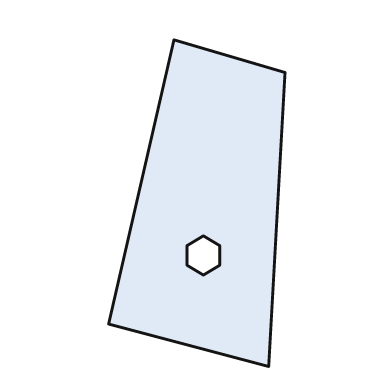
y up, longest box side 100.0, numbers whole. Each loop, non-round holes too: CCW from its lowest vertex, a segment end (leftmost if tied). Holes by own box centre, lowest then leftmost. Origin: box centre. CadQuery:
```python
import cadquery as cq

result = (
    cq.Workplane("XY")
    .moveTo(22.0, -50.0)
    .lineTo(27.0, 40.0)
    .lineTo(-7.0, 50.0)
    .lineTo(-27.0, -37.0)
    .close()
    .moveTo(2.0, -22.0)
    .lineTo(7.0, -19.0)
    .lineTo(7.0, -13.0)
    .lineTo(2.0, -10.0)
    .lineTo(-3.0, -13.0)
    .lineTo(-3.0, -19.0)
    .close()
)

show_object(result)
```